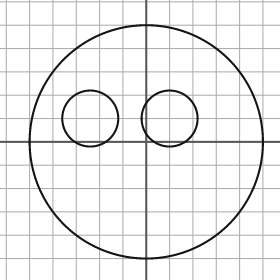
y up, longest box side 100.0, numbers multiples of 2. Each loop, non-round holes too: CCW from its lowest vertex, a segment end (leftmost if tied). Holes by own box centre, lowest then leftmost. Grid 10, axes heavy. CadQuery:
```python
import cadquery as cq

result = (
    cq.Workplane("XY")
    .moveTo(0.0, 0.0)
    .circle(50.0)
    .moveTo(-24.0, 10.0)
    .circle(12.0)
    .moveTo(10.0, 10.0)
    .circle(12.0)
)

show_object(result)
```